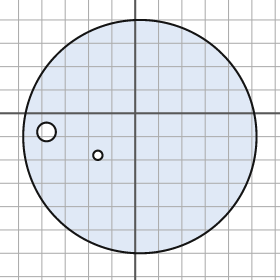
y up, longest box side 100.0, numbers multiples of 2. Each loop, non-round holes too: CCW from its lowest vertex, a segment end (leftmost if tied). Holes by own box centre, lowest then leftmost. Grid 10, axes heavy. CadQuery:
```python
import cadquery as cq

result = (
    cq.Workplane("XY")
    .moveTo(2.0, -10.0)
    .circle(50.0)
    .moveTo(-16.0, -18.0)
    .circle(2.0)
    .moveTo(-38.0, -8.0)
    .circle(4.0)
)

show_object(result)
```